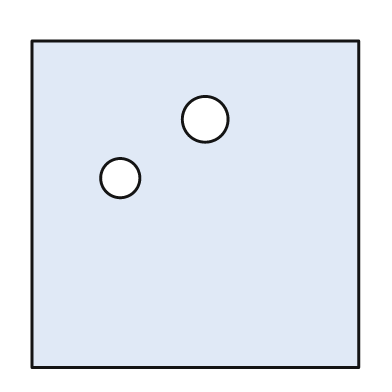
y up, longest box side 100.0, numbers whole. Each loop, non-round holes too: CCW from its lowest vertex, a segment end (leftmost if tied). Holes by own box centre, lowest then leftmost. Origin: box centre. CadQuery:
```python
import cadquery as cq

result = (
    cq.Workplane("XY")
    .moveTo(-50.0, -50.0)
    .lineTo(50.0, -50.0)
    .lineTo(50.0, 50.0)
    .lineTo(-50.0, 50.0)
    .close()
    .moveTo(-23.0, 8.0)
    .circle(6.0)
    .moveTo(3.0, 26.0)
    .circle(7.0)
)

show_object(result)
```